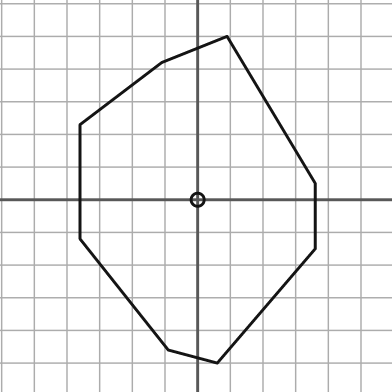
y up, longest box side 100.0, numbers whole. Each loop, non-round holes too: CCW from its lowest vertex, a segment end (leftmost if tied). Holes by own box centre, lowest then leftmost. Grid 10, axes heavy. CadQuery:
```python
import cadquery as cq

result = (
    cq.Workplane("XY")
    .moveTo(6.0, -50.0)
    .lineTo(36.0, -15.0)
    .lineTo(36.0, 5.0)
    .lineTo(9.0, 50.0)
    .lineTo(-11.0, 42.0)
    .lineTo(-36.0, 23.0)
    .lineTo(-36.0, -12.0)
    .lineTo(-9.0, -46.0)
    .close()
    .moveTo(0.0, 0.0)
    .circle(2.0)
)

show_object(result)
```